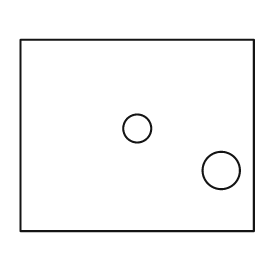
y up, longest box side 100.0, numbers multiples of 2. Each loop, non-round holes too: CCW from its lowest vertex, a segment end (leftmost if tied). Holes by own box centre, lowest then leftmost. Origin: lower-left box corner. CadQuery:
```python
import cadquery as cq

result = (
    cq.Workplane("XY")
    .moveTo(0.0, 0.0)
    .lineTo(100.0, 0.0)
    .lineTo(100.0, 82.0)
    .lineTo(0.0, 82.0)
    .close()
    .moveTo(86.0, 26.0)
    .circle(8.0)
    .moveTo(50.0, 44.0)
    .circle(6.0)
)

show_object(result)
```